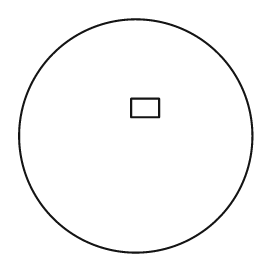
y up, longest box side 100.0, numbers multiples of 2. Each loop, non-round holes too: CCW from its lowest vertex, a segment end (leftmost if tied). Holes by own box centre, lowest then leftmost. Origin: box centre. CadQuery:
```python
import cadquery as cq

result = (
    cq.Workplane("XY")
    .moveTo(0.0, 0.0)
    .circle(50.0)
    .moveTo(-2.0, 8.0)
    .lineTo(10.0, 8.0)
    .lineTo(10.0, 16.0)
    .lineTo(-2.0, 16.0)
    .close()
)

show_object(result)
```